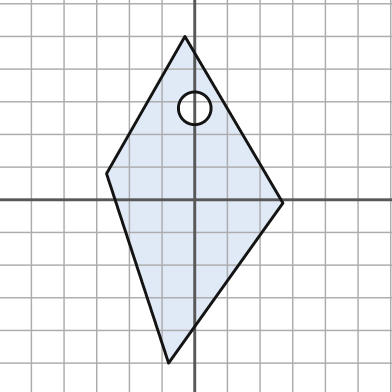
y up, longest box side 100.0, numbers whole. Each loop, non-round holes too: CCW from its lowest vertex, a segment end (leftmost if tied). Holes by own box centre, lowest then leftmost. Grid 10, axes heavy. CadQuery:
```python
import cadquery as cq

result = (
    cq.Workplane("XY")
    .moveTo(-8.0, -50.0)
    .lineTo(27.0, -1.0)
    .lineTo(-3.0, 50.0)
    .lineTo(-27.0, 8.0)
    .close()
    .moveTo(0.0, 28.0)
    .circle(5.0)
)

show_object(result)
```